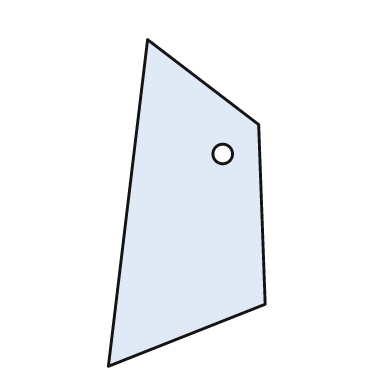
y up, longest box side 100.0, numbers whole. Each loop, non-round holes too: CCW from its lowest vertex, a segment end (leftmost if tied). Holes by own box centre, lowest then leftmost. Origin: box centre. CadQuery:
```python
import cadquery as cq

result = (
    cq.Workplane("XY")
    .moveTo(-24.0, -50.0)
    .lineTo(24.0, -31.0)
    .lineTo(22.0, 24.0)
    .lineTo(-12.0, 50.0)
    .close()
    .moveTo(11.0, 15.0)
    .circle(3.0)
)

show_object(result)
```